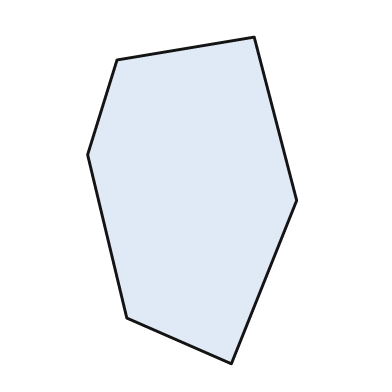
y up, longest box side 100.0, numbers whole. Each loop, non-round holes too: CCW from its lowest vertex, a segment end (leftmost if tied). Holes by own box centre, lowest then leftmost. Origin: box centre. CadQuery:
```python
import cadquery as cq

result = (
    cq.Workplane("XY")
    .moveTo(12.0, -50.0)
    .lineTo(32.0, 0.0)
    .lineTo(19.0, 50.0)
    .lineTo(-23.0, 43.0)
    .lineTo(-32.0, 14.0)
    .lineTo(-20.0, -36.0)
    .close()
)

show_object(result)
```